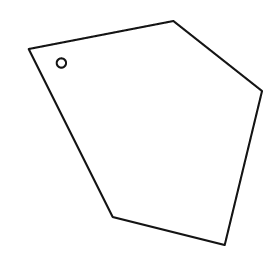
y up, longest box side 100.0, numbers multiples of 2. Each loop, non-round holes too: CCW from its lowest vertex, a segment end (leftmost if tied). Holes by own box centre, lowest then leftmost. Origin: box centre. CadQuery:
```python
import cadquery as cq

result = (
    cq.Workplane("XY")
    .moveTo(34.0, -48.0)
    .lineTo(50.0, 18.0)
    .lineTo(12.0, 48.0)
    .lineTo(-50.0, 36.0)
    .lineTo(-14.0, -36.0)
    .close()
    .moveTo(-36.0, 30.0)
    .circle(2.0)
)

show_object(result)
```